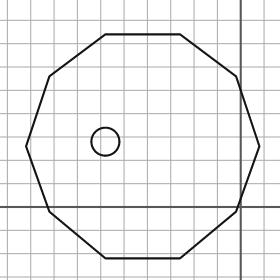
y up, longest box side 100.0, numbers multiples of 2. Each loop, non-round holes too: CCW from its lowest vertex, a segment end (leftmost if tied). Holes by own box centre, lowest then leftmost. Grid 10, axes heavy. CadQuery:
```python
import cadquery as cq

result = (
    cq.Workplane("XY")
    .moveTo(-58.0, -22.0)
    .lineTo(-26.0, -22.0)
    .lineTo(-2.0, -2.0)
    .lineTo(8.0, 26.0)
    .lineTo(-2.0, 56.0)
    .lineTo(-26.0, 74.0)
    .lineTo(-58.0, 74.0)
    .lineTo(-82.0, 56.0)
    .lineTo(-92.0, 26.0)
    .lineTo(-82.0, -2.0)
    .close()
    .moveTo(-58.0, 28.0)
    .circle(6.0)
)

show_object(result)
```